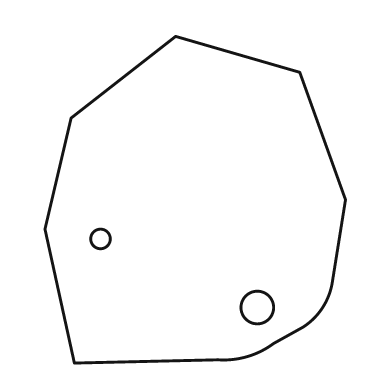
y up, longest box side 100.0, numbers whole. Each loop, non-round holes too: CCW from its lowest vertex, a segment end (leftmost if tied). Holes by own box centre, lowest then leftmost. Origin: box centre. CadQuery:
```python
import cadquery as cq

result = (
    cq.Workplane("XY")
    .moveTo(-37.0, -50.0)
    .lineTo(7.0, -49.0)
    .threePointArc((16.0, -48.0), (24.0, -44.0))
    .lineTo(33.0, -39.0)
    .threePointArc((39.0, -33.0), (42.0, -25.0))
    .lineTo(46.0, 0.0)
    .lineTo(32.0, 39.0)
    .lineTo(-6.0, 50.0)
    .lineTo(-38.0, 25.0)
    .lineTo(-46.0, -9.0)
    .close()
    .moveTo(19.0, -33.0)
    .circle(5.0)
    .moveTo(-29.0, -12.0)
    .circle(3.0)
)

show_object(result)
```